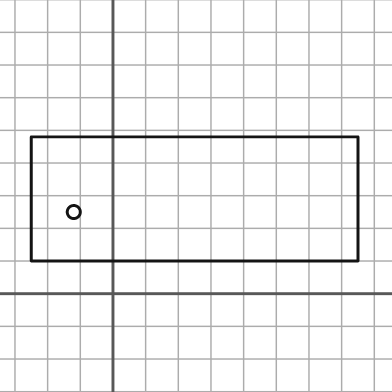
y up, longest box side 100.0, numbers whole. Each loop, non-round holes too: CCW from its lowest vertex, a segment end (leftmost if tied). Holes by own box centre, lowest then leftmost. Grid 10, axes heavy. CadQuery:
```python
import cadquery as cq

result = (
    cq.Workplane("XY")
    .moveTo(-25.0, 10.0)
    .lineTo(75.0, 10.0)
    .lineTo(75.0, 48.0)
    .lineTo(-25.0, 48.0)
    .close()
    .moveTo(-12.0, 25.0)
    .circle(2.0)
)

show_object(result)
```